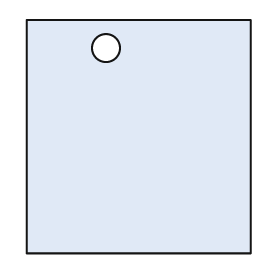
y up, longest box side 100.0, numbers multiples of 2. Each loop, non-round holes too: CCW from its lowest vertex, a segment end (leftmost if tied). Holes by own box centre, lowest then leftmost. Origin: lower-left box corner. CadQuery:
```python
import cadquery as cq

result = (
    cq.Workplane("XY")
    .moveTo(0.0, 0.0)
    .lineTo(96.0, 0.0)
    .lineTo(96.0, 100.0)
    .lineTo(0.0, 100.0)
    .close()
    .moveTo(34.0, 88.0)
    .circle(6.0)
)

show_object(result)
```